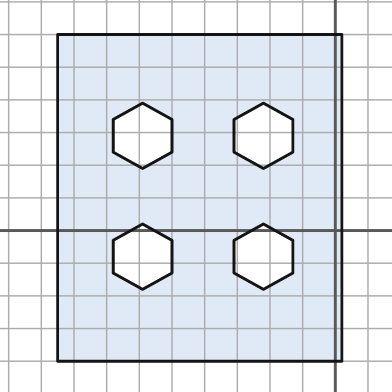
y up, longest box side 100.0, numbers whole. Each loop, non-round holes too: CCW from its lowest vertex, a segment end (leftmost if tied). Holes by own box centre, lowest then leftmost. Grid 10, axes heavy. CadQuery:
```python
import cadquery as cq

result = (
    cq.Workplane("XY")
    .moveTo(-85.0, -40.0)
    .lineTo(2.0, -40.0)
    .lineTo(2.0, 60.0)
    .lineTo(-85.0, 60.0)
    .close()
    .moveTo(-59.0, -18.0)
    .lineTo(-50.0, -13.0)
    .lineTo(-50.0, -3.0)
    .lineTo(-59.0, 2.0)
    .lineTo(-68.0, -3.0)
    .lineTo(-68.0, -13.0)
    .close()
    .moveTo(-22.0, -18.0)
    .lineTo(-13.0, -13.0)
    .lineTo(-13.0, -3.0)
    .lineTo(-22.0, 2.0)
    .lineTo(-31.0, -3.0)
    .lineTo(-31.0, -13.0)
    .close()
    .moveTo(-59.0, 19.0)
    .lineTo(-50.0, 24.0)
    .lineTo(-50.0, 34.0)
    .lineTo(-59.0, 39.0)
    .lineTo(-68.0, 34.0)
    .lineTo(-68.0, 24.0)
    .close()
    .moveTo(-22.0, 19.0)
    .lineTo(-13.0, 24.0)
    .lineTo(-13.0, 34.0)
    .lineTo(-22.0, 39.0)
    .lineTo(-31.0, 34.0)
    .lineTo(-31.0, 24.0)
    .close()
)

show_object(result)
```